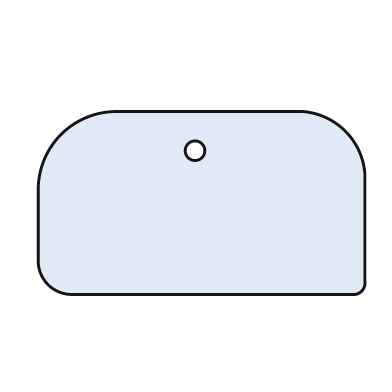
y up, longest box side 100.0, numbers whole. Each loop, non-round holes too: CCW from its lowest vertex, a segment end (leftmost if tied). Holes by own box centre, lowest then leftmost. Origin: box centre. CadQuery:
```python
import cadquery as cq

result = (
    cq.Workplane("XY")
    .moveTo(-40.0, -28.0)
    .lineTo(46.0, -28.0)
    .threePointArc((49.0, -27.0), (50.0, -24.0))
    .lineTo(50.0, 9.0)
    .threePointArc((44.0, 22.0), (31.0, 28.0))
    .lineTo(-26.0, 28.0)
    .threePointArc((-43.0, 21.0), (-50.0, 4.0))
    .lineTo(-50.0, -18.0)
    .threePointArc((-47.0, -25.0), (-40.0, -28.0))
    .close()
    .moveTo(-2.0, 16.0)
    .circle(3.0)
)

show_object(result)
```